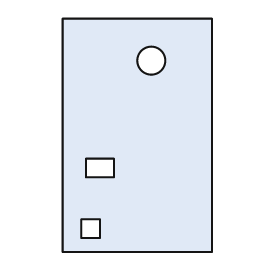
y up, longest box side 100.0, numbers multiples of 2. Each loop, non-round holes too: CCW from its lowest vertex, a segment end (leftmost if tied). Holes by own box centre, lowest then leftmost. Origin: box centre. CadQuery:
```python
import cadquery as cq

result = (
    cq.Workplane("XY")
    .moveTo(-32.0, -50.0)
    .lineTo(32.0, -50.0)
    .lineTo(32.0, 50.0)
    .lineTo(-32.0, 50.0)
    .close()
    .moveTo(-24.0, -44.0)
    .lineTo(-16.0, -44.0)
    .lineTo(-16.0, -36.0)
    .lineTo(-24.0, -36.0)
    .close()
    .moveTo(-22.0, -18.0)
    .lineTo(-10.0, -18.0)
    .lineTo(-10.0, -10.0)
    .lineTo(-22.0, -10.0)
    .close()
    .moveTo(6.0, 32.0)
    .circle(6.0)
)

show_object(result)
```